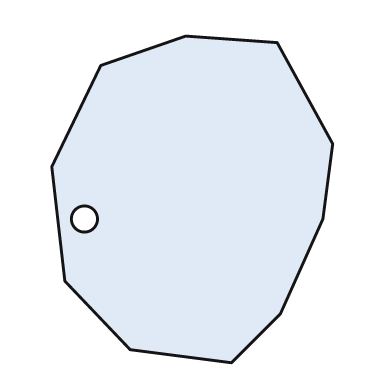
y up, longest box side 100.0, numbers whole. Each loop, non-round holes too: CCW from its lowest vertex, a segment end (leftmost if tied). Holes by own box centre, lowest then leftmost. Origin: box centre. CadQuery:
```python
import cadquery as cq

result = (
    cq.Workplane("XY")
    .moveTo(12.0, -50.0)
    .lineTo(27.0, -35.0)
    .lineTo(40.0, -6.0)
    .lineTo(43.0, 17.0)
    .lineTo(26.0, 48.0)
    .lineTo(-2.0, 50.0)
    .lineTo(-28.0, 41.0)
    .lineTo(-43.0, 10.0)
    .lineTo(-39.0, -25.0)
    .lineTo(-19.0, -46.0)
    .close()
    .moveTo(-33.0, -6.0)
    .circle(4.0)
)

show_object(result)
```